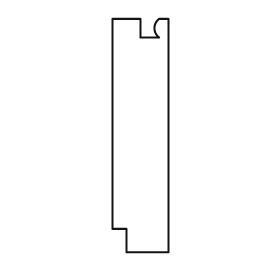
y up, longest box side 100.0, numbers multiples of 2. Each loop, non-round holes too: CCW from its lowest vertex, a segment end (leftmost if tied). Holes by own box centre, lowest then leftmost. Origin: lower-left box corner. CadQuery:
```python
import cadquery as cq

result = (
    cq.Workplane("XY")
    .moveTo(6.0, 0.0)
    .lineTo(24.0, 0.0)
    .lineTo(24.0, 100.0)
    .lineTo(20.0, 100.0)
    .threePointArc((18.0, 96.0), (20.0, 92.0))
    .lineTo(12.0, 92.0)
    .lineTo(12.0, 100.0)
    .lineTo(0.0, 100.0)
    .lineTo(0.0, 10.0)
    .lineTo(6.0, 10.0)
    .close()
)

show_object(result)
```